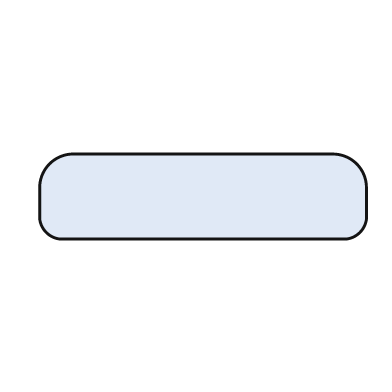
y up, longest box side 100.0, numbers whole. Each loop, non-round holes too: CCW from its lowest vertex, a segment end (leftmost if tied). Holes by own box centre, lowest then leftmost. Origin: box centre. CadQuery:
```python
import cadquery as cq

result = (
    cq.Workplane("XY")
    .moveTo(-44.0, -13.0)
    .lineTo(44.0, -13.0)
    .threePointArc((48.0, -11.0), (50.0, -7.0))
    .lineTo(50.0, 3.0)
    .threePointArc((47.0, 10.0), (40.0, 13.0))
    .lineTo(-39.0, 13.0)
    .threePointArc((-47.0, 10.0), (-50.0, 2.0))
    .lineTo(-50.0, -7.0)
    .threePointArc((-48.0, -11.0), (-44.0, -13.0))
    .close()
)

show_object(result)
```